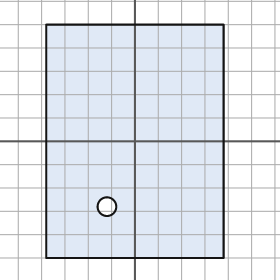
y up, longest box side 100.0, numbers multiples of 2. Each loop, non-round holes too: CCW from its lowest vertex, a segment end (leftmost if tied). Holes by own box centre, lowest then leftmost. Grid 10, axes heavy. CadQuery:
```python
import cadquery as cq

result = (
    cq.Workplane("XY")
    .moveTo(-38.0, -50.0)
    .lineTo(38.0, -50.0)
    .lineTo(38.0, 50.0)
    .lineTo(-38.0, 50.0)
    .close()
    .moveTo(-12.0, -28.0)
    .circle(4.0)
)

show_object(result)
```